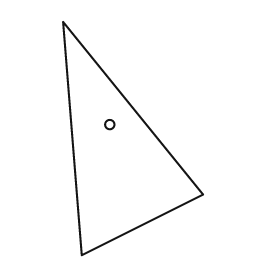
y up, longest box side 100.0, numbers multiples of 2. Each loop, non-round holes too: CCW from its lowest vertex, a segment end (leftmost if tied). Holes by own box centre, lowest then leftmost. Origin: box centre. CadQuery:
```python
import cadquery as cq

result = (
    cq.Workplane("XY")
    .moveTo(-22.0, -50.0)
    .lineTo(30.0, -24.0)
    .lineTo(-30.0, 50.0)
    .close()
    .moveTo(-10.0, 6.0)
    .circle(2.0)
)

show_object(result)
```